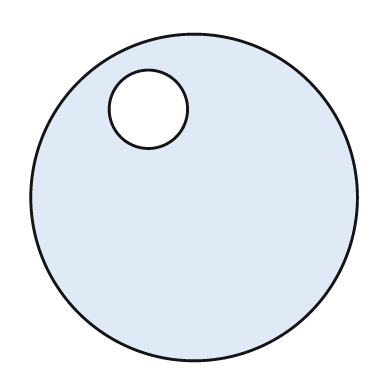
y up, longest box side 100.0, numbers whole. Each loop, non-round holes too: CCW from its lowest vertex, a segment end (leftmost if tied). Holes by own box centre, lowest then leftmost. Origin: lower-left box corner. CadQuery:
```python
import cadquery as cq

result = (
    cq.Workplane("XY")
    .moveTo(50.0, 50.0)
    .circle(50.0)
    .moveTo(36.0, 77.0)
    .circle(12.0)
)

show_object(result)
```